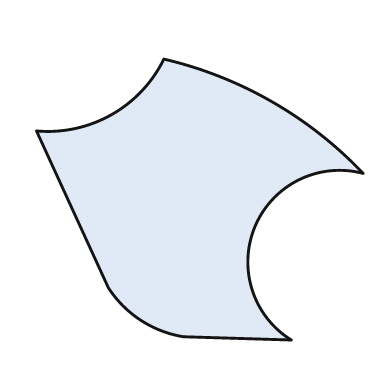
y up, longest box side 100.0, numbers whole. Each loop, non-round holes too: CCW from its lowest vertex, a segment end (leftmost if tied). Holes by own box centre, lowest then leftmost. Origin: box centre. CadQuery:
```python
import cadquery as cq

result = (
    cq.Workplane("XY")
    .moveTo(28.0, -43.0)
    .threePointArc((17.0, -8.0), (50.0, 8.0))
    .threePointArc((22.0, 30.0), (-11.0, 43.0))
    .threePointArc((-27.0, 26.0), (-50.0, 21.0))
    .lineTo(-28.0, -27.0)
    .threePointArc((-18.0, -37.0), (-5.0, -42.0))
    .close()
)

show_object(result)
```